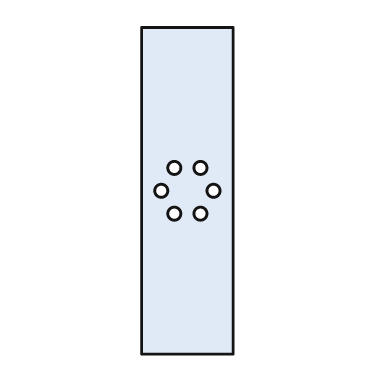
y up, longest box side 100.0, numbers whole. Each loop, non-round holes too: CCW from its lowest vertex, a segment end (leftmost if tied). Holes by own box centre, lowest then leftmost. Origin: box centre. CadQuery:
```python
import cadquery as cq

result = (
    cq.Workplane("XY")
    .moveTo(-14.0, -50.0)
    .lineTo(14.0, -50.0)
    .lineTo(14.0, 50.0)
    .lineTo(-14.0, 50.0)
    .close()
    .moveTo(-4.0, -7.0)
    .circle(2.0)
    .moveTo(4.0, -7.0)
    .circle(2.0)
    .moveTo(-8.0, 0.0)
    .circle(2.0)
    .moveTo(8.0, 0.0)
    .circle(2.0)
    .moveTo(-4.0, 7.0)
    .circle(2.0)
    .moveTo(4.0, 7.0)
    .circle(2.0)
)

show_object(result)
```